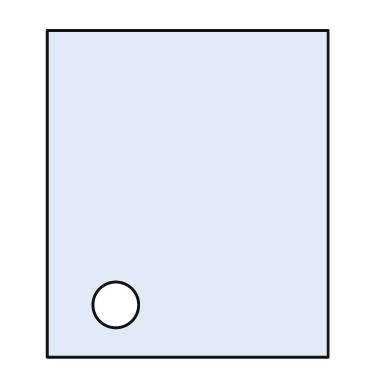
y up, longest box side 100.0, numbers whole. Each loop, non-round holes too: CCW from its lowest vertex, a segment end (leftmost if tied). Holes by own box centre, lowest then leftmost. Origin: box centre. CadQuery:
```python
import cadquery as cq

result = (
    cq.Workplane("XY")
    .moveTo(-43.0, -50.0)
    .lineTo(43.0, -50.0)
    .lineTo(43.0, 50.0)
    .lineTo(-43.0, 50.0)
    .close()
    .moveTo(-22.0, -34.0)
    .circle(7.0)
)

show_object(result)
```